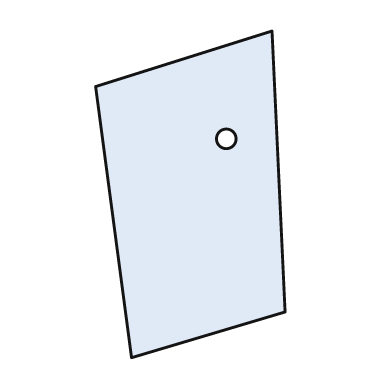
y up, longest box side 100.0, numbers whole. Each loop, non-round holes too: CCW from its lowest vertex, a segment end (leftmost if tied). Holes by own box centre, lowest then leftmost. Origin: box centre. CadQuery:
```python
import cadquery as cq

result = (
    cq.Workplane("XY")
    .moveTo(-18.0, -50.0)
    .lineTo(29.0, -36.0)
    .lineTo(25.0, 50.0)
    .lineTo(-29.0, 33.0)
    .close()
    .moveTo(11.0, 17.0)
    .circle(3.0)
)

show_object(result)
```